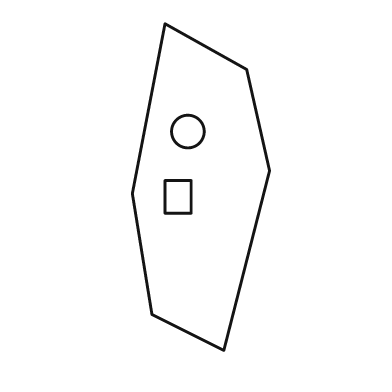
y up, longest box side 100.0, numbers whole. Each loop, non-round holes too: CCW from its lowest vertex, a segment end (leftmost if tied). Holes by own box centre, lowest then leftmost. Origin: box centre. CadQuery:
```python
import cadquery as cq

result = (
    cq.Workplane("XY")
    .moveTo(7.0, -50.0)
    .lineTo(21.0, 5.0)
    .lineTo(14.0, 36.0)
    .lineTo(-11.0, 50.0)
    .lineTo(-21.0, -2.0)
    .lineTo(-15.0, -39.0)
    .close()
    .moveTo(-11.0, -8.0)
    .lineTo(-3.0, -8.0)
    .lineTo(-3.0, 2.0)
    .lineTo(-11.0, 2.0)
    .close()
    .moveTo(-4.0, 17.0)
    .circle(5.0)
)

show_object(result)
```